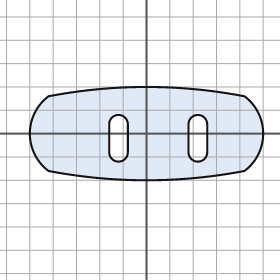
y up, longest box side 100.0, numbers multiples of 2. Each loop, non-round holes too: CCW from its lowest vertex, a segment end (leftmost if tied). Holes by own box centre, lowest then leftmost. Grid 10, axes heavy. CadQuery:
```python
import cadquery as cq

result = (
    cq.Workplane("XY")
    .moveTo(-42.0, -16.0)
    .threePointArc((0.0, -20.0), (42.0, -16.0))
    .threePointArc((50.0, 0.0), (42.0, 16.0))
    .threePointArc((0.0, 20.0), (-42.0, 16.0))
    .threePointArc((-50.0, 0.0), (-42.0, -16.0))
    .close()
    .moveTo(-16.0, -8.0)
    .threePointArc((-12.0, -12.0), (-8.0, -8.0))
    .lineTo(-8.0, 4.0)
    .threePointArc((-12.0, 8.0), (-16.0, 4.0))
    .close()
    .moveTo(18.0, -8.0)
    .threePointArc((22.0, -12.0), (26.0, -8.0))
    .lineTo(26.0, 4.0)
    .threePointArc((22.0, 8.0), (18.0, 4.0))
    .close()
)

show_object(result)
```